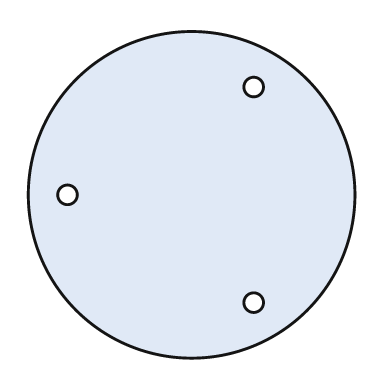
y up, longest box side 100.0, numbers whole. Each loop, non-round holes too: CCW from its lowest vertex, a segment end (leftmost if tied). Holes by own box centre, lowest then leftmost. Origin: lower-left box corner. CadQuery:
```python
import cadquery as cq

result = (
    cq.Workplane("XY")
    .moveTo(50.0, 50.0)
    .circle(50.0)
    .moveTo(69.0, 17.0)
    .circle(3.0)
    .moveTo(12.0, 50.0)
    .circle(3.0)
    .moveTo(69.0, 83.0)
    .circle(3.0)
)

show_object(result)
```